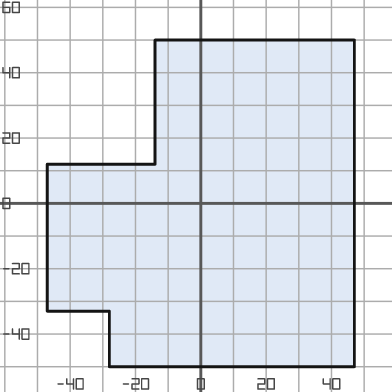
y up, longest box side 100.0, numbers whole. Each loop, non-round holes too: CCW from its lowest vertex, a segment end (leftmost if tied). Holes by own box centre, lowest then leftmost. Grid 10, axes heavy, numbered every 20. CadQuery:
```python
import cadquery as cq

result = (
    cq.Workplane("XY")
    .moveTo(-28.0, -50.0)
    .lineTo(47.0, -50.0)
    .lineTo(47.0, 50.0)
    .lineTo(-14.0, 50.0)
    .lineTo(-14.0, 12.0)
    .lineTo(-47.0, 12.0)
    .lineTo(-47.0, -33.0)
    .lineTo(-28.0, -33.0)
    .close()
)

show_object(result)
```